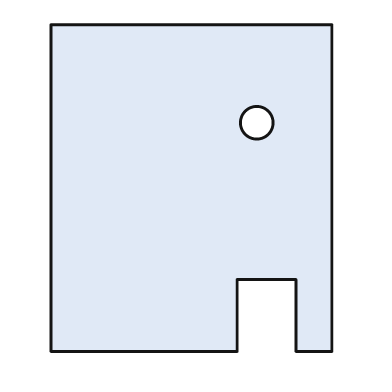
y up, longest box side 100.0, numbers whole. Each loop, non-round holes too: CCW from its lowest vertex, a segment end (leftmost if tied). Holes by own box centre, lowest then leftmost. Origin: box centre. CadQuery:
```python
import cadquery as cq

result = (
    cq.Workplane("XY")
    .moveTo(-43.0, -50.0)
    .lineTo(14.0, -50.0)
    .lineTo(14.0, -28.0)
    .lineTo(32.0, -28.0)
    .lineTo(32.0, -50.0)
    .lineTo(43.0, -50.0)
    .lineTo(43.0, 50.0)
    .lineTo(-43.0, 50.0)
    .close()
    .moveTo(20.0, 20.0)
    .circle(5.0)
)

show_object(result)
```